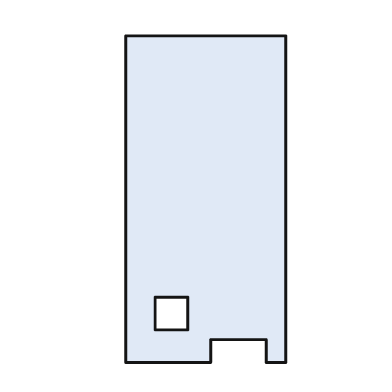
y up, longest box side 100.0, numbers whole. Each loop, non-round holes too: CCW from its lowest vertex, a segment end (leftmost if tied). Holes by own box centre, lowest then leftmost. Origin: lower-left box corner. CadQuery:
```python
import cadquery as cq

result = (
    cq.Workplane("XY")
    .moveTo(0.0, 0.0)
    .lineTo(26.0, 0.0)
    .lineTo(26.0, 7.0)
    .lineTo(43.0, 7.0)
    .lineTo(43.0, 0.0)
    .lineTo(49.0, 0.0)
    .lineTo(49.0, 100.0)
    .lineTo(0.0, 100.0)
    .close()
    .moveTo(9.0, 10.0)
    .lineTo(19.0, 10.0)
    .lineTo(19.0, 20.0)
    .lineTo(9.0, 20.0)
    .close()
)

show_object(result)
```